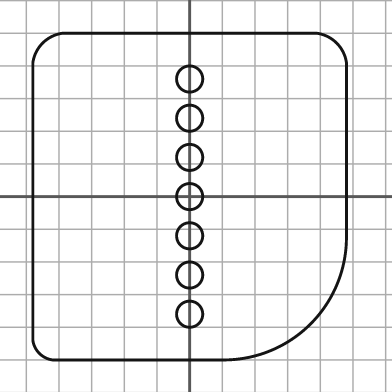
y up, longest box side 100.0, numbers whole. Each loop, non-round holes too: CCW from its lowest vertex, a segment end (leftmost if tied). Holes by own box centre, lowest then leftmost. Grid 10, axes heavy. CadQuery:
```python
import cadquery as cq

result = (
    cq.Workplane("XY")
    .moveTo(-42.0, -50.0)
    .lineTo(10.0, -50.0)
    .threePointArc((37.0, -39.0), (48.0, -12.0))
    .lineTo(48.0, 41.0)
    .threePointArc((45.0, 47.0), (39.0, 50.0))
    .lineTo(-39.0, 50.0)
    .threePointArc((-45.0, 47.0), (-48.0, 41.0))
    .lineTo(-48.0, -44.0)
    .threePointArc((-46.0, -48.0), (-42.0, -50.0))
    .close()
    .moveTo(0.0, -36.0)
    .circle(4.0)
    .moveTo(0.0, -24.0)
    .circle(4.0)
    .moveTo(0.0, -12.0)
    .circle(4.0)
    .moveTo(0.0, 0.0)
    .circle(4.0)
    .moveTo(0.0, 12.0)
    .circle(4.0)
    .moveTo(0.0, 24.0)
    .circle(4.0)
    .moveTo(0.0, 36.0)
    .circle(4.0)
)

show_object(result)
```